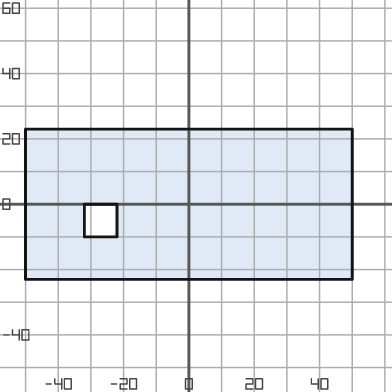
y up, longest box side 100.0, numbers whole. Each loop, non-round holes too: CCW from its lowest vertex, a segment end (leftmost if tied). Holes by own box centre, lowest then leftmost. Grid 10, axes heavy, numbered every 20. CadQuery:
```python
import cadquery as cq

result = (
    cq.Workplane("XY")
    .moveTo(-50.0, -23.0)
    .lineTo(50.0, -23.0)
    .lineTo(50.0, 23.0)
    .lineTo(-50.0, 23.0)
    .close()
    .moveTo(-32.0, -10.0)
    .lineTo(-22.0, -10.0)
    .lineTo(-22.0, 0.0)
    .lineTo(-32.0, 0.0)
    .close()
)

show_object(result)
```